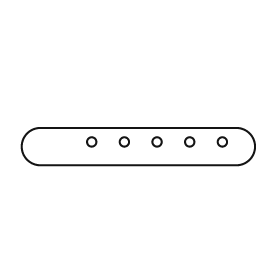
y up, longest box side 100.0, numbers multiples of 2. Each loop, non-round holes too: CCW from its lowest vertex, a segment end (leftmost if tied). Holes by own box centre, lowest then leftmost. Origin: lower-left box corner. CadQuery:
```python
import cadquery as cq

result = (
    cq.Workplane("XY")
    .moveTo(8.0, 0.0)
    .lineTo(92.0, 0.0)
    .threePointArc((100.0, 8.0), (92.0, 16.0))
    .lineTo(8.0, 16.0)
    .threePointArc((0.0, 8.0), (8.0, 0.0))
    .close()
    .moveTo(30.0, 10.0)
    .circle(2.0)
    .moveTo(44.0, 10.0)
    .circle(2.0)
    .moveTo(58.0, 10.0)
    .circle(2.0)
    .moveTo(72.0, 10.0)
    .circle(2.0)
    .moveTo(86.0, 10.0)
    .circle(2.0)
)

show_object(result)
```